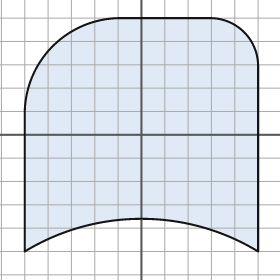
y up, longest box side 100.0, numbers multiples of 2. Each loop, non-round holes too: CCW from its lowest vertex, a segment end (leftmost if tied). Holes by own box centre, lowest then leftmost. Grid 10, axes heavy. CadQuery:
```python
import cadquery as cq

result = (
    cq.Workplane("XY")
    .moveTo(-50.0, -50.0)
    .threePointArc((0.0, -36.0), (50.0, -50.0))
    .lineTo(50.0, 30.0)
    .threePointArc((44.0, 44.0), (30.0, 50.0))
    .lineTo(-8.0, 50.0)
    .threePointArc((-38.0, 38.0), (-50.0, 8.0))
    .close()
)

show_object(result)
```